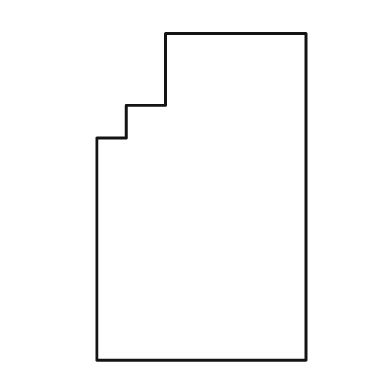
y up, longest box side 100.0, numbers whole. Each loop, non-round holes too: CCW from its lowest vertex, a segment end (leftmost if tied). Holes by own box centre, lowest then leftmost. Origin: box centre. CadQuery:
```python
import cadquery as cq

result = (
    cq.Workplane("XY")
    .moveTo(-32.0, -50.0)
    .lineTo(32.0, -50.0)
    .lineTo(32.0, 50.0)
    .lineTo(-11.0, 50.0)
    .lineTo(-11.0, 28.0)
    .lineTo(-23.0, 28.0)
    .lineTo(-23.0, 18.0)
    .lineTo(-32.0, 18.0)
    .close()
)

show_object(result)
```